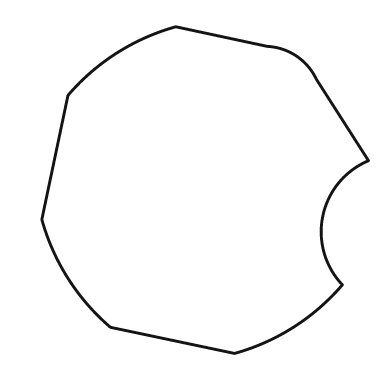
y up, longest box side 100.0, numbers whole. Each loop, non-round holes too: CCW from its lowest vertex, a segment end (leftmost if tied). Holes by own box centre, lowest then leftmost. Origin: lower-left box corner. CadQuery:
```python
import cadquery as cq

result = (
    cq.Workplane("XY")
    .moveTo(59.0, 0.0)
    .threePointArc((77.0, 8.0), (92.0, 21.0))
    .threePointArc((86.0, 42.0), (100.0, 59.0))
    .lineTo(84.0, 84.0)
    .threePointArc((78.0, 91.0), (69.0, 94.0))
    .lineTo(41.0, 100.0)
    .threePointArc((23.0, 92.0), (8.0, 79.0))
    .lineTo(0.0, 41.0)
    .threePointArc((8.0, 23.0), (21.0, 8.0))
    .close()
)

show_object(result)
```